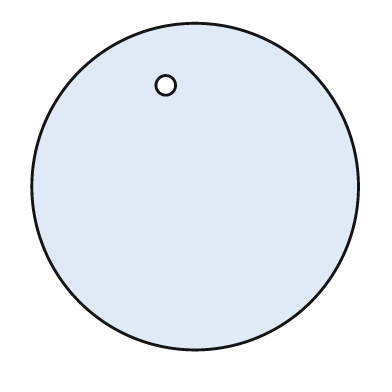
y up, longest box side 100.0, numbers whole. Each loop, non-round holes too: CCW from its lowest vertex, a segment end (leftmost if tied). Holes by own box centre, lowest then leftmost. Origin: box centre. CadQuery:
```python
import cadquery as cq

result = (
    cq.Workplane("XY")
    .moveTo(0.0, 0.0)
    .circle(50.0)
    .moveTo(-9.0, 31.0)
    .circle(3.0)
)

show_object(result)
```